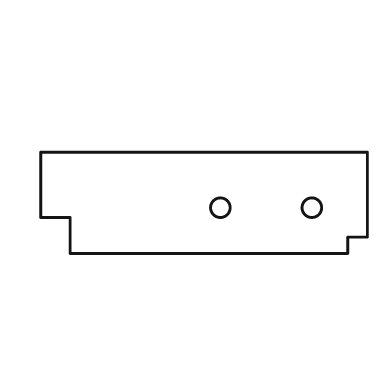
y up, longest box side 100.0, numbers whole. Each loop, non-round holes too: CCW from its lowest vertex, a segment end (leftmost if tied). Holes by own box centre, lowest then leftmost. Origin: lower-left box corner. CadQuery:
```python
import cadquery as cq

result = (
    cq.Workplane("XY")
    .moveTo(9.0, 0.0)
    .lineTo(94.0, 0.0)
    .lineTo(94.0, 5.0)
    .lineTo(100.0, 5.0)
    .lineTo(100.0, 31.0)
    .lineTo(0.0, 31.0)
    .lineTo(0.0, 11.0)
    .lineTo(9.0, 11.0)
    .close()
    .moveTo(55.0, 14.0)
    .circle(3.0)
    .moveTo(83.0, 14.0)
    .circle(3.0)
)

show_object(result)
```